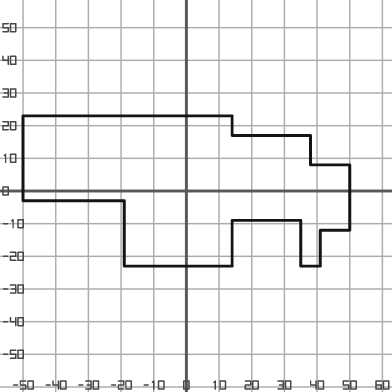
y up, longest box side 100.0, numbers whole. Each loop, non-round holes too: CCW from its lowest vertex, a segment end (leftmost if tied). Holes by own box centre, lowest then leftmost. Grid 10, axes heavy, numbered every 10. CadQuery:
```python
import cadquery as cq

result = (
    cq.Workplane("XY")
    .moveTo(-19.0, -23.0)
    .lineTo(14.0, -23.0)
    .lineTo(14.0, -9.0)
    .lineTo(35.0, -9.0)
    .lineTo(35.0, -23.0)
    .lineTo(41.0, -23.0)
    .lineTo(41.0, -12.0)
    .lineTo(50.0, -12.0)
    .lineTo(50.0, 8.0)
    .lineTo(38.0, 8.0)
    .lineTo(38.0, 17.0)
    .lineTo(14.0, 17.0)
    .lineTo(14.0, 23.0)
    .lineTo(-50.0, 23.0)
    .lineTo(-50.0, -3.0)
    .lineTo(-19.0, -3.0)
    .close()
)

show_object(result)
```